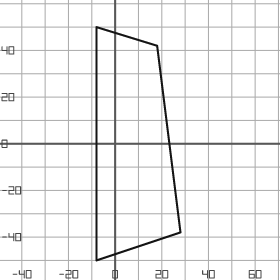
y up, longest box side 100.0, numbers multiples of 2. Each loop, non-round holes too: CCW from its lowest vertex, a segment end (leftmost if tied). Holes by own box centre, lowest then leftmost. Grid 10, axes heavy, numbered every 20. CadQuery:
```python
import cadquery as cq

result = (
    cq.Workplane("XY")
    .moveTo(-8.0, -50.0)
    .lineTo(28.0, -38.0)
    .lineTo(18.0, 42.0)
    .lineTo(-8.0, 50.0)
    .close()
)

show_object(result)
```